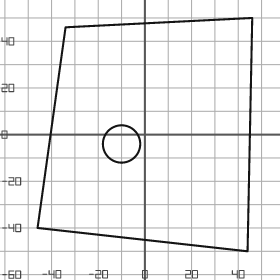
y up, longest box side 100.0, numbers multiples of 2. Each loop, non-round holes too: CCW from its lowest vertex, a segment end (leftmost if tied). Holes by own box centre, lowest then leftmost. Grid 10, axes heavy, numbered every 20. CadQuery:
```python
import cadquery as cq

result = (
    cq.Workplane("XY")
    .moveTo(44.0, -50.0)
    .lineTo(46.0, 50.0)
    .lineTo(-34.0, 46.0)
    .lineTo(-46.0, -40.0)
    .close()
    .moveTo(-10.0, -4.0)
    .circle(8.0)
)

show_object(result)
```